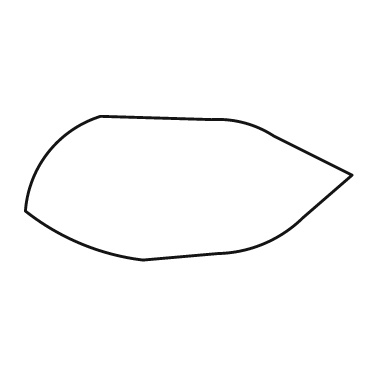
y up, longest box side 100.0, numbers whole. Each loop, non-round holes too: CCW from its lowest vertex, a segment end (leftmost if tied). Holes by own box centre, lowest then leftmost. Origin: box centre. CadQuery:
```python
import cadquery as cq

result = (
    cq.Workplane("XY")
    .moveTo(-14.0, -22.0)
    .lineTo(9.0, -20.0)
    .threePointArc((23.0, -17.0), (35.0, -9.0))
    .lineTo(50.0, 4.0)
    .lineTo(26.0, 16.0)
    .threePointArc((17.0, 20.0), (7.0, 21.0))
    .lineTo(-27.0, 22.0)
    .threePointArc((-43.0, 11.0), (-50.0, -7.0))
    .threePointArc((-33.0, -17.0), (-14.0, -22.0))
    .close()
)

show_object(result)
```